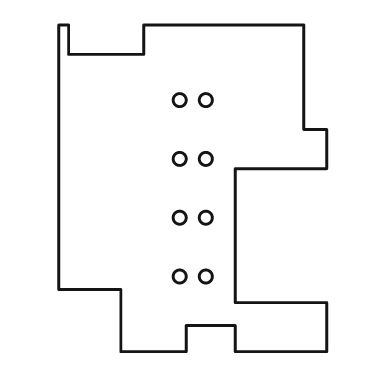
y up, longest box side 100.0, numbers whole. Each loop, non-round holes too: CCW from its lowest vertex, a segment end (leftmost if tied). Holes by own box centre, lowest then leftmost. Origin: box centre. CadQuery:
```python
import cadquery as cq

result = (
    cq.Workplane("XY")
    .moveTo(-22.0, -50.0)
    .lineTo(-2.0, -50.0)
    .lineTo(-2.0, -42.0)
    .lineTo(13.0, -42.0)
    .lineTo(13.0, -50.0)
    .lineTo(41.0, -50.0)
    .lineTo(41.0, -35.0)
    .lineTo(13.0, -35.0)
    .lineTo(13.0, 6.0)
    .lineTo(41.0, 6.0)
    .lineTo(41.0, 18.0)
    .lineTo(34.0, 18.0)
    .lineTo(34.0, 50.0)
    .lineTo(-15.0, 50.0)
    .lineTo(-15.0, 41.0)
    .lineTo(-38.0, 41.0)
    .lineTo(-38.0, 50.0)
    .lineTo(-41.0, 50.0)
    .lineTo(-41.0, -31.0)
    .lineTo(-22.0, -31.0)
    .close()
    .moveTo(-4.0, -27.0)
    .circle(2.0)
    .moveTo(4.0, -27.0)
    .circle(2.0)
    .moveTo(-4.0, -9.0)
    .circle(2.0)
    .moveTo(4.0, -9.0)
    .circle(2.0)
    .moveTo(-4.0, 9.0)
    .circle(2.0)
    .moveTo(4.0, 9.0)
    .circle(2.0)
    .moveTo(-4.0, 27.0)
    .circle(2.0)
    .moveTo(4.0, 27.0)
    .circle(2.0)
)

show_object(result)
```